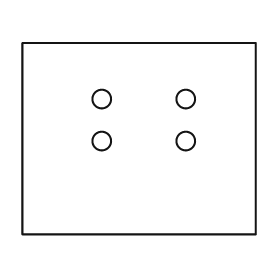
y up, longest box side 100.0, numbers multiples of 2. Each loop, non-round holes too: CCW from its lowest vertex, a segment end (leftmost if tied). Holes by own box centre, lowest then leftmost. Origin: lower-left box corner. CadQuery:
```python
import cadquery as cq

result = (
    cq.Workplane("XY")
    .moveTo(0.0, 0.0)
    .lineTo(100.0, 0.0)
    .lineTo(100.0, 82.0)
    .lineTo(0.0, 82.0)
    .close()
    .moveTo(34.0, 40.0)
    .circle(4.0)
    .moveTo(70.0, 40.0)
    .circle(4.0)
    .moveTo(34.0, 58.0)
    .circle(4.0)
    .moveTo(70.0, 58.0)
    .circle(4.0)
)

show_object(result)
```